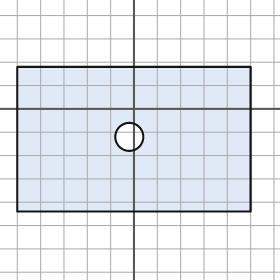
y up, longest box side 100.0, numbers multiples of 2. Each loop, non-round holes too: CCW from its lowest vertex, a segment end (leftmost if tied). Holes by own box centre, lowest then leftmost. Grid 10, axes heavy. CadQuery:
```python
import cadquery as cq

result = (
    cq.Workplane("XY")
    .moveTo(-50.0, -44.0)
    .lineTo(50.0, -44.0)
    .lineTo(50.0, 18.0)
    .lineTo(-50.0, 18.0)
    .close()
    .moveTo(-2.0, -12.0)
    .circle(6.0)
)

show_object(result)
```